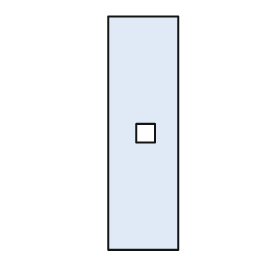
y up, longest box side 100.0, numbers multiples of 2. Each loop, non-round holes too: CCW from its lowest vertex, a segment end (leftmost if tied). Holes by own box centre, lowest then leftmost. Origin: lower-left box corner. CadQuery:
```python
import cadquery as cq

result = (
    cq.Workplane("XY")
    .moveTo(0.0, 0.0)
    .lineTo(30.0, 0.0)
    .lineTo(30.0, 100.0)
    .lineTo(0.0, 100.0)
    .close()
    .moveTo(12.0, 46.0)
    .lineTo(20.0, 46.0)
    .lineTo(20.0, 54.0)
    .lineTo(12.0, 54.0)
    .close()
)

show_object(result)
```